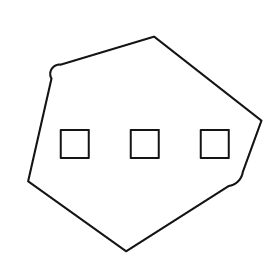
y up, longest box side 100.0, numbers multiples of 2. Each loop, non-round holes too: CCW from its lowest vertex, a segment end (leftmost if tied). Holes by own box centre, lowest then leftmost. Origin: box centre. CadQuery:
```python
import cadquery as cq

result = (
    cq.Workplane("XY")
    .moveTo(-8.0, -46.0)
    .lineTo(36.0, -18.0)
    .threePointArc((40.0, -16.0), (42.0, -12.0))
    .lineTo(50.0, 10.0)
    .lineTo(4.0, 46.0)
    .lineTo(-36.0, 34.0)
    .threePointArc((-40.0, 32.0), (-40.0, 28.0))
    .lineTo(-50.0, -16.0)
    .close()
    .moveTo(-36.0, -6.0)
    .lineTo(-24.0, -6.0)
    .lineTo(-24.0, 6.0)
    .lineTo(-36.0, 6.0)
    .close()
    .moveTo(-6.0, -6.0)
    .lineTo(6.0, -6.0)
    .lineTo(6.0, 6.0)
    .lineTo(-6.0, 6.0)
    .close()
    .moveTo(24.0, -6.0)
    .lineTo(36.0, -6.0)
    .lineTo(36.0, 6.0)
    .lineTo(24.0, 6.0)
    .close()
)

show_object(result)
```